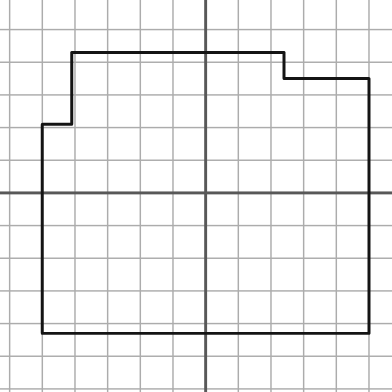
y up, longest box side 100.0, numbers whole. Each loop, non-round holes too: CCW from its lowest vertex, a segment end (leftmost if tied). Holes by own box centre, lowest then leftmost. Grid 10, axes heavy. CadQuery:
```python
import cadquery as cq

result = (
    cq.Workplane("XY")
    .moveTo(-50.0, -43.0)
    .lineTo(50.0, -43.0)
    .lineTo(50.0, 35.0)
    .lineTo(24.0, 35.0)
    .lineTo(24.0, 43.0)
    .lineTo(-41.0, 43.0)
    .lineTo(-41.0, 21.0)
    .lineTo(-50.0, 21.0)
    .close()
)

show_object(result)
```